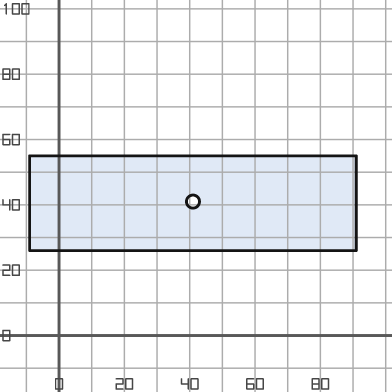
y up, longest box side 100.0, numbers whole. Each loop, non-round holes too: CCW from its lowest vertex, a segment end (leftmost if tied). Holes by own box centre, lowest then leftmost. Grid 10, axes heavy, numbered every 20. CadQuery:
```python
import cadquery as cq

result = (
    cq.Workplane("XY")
    .moveTo(-9.0, 26.0)
    .lineTo(91.0, 26.0)
    .lineTo(91.0, 55.0)
    .lineTo(-9.0, 55.0)
    .close()
    .moveTo(41.0, 41.0)
    .circle(2.0)
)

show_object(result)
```